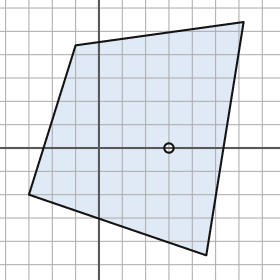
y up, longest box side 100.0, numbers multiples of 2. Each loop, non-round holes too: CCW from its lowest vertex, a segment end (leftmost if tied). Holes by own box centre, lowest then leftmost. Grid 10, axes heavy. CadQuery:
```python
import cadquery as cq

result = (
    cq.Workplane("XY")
    .moveTo(46.0, -46.0)
    .lineTo(62.0, 54.0)
    .lineTo(-10.0, 44.0)
    .lineTo(-30.0, -20.0)
    .close()
    .moveTo(30.0, 0.0)
    .circle(2.0)
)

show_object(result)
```